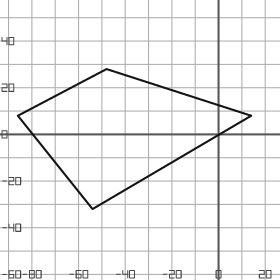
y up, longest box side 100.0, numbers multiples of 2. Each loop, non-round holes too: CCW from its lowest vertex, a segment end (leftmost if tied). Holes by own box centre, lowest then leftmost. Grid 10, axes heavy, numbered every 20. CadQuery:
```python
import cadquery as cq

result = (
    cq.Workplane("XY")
    .moveTo(-54.0, -32.0)
    .lineTo(14.0, 8.0)
    .lineTo(-48.0, 28.0)
    .lineTo(-86.0, 8.0)
    .close()
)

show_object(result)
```